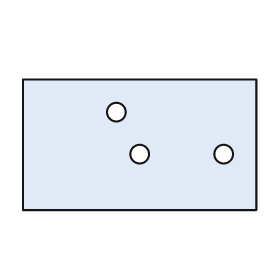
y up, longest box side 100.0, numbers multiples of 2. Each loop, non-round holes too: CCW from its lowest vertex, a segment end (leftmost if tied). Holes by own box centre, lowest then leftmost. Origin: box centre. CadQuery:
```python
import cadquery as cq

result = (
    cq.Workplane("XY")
    .moveTo(-50.0, -28.0)
    .lineTo(50.0, -28.0)
    .lineTo(50.0, 28.0)
    .lineTo(-50.0, 28.0)
    .close()
    .moveTo(0.0, -4.0)
    .circle(4.0)
    .moveTo(36.0, -4.0)
    .circle(4.0)
    .moveTo(-10.0, 14.0)
    .circle(4.0)
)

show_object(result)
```